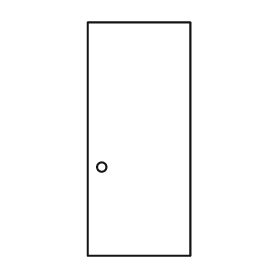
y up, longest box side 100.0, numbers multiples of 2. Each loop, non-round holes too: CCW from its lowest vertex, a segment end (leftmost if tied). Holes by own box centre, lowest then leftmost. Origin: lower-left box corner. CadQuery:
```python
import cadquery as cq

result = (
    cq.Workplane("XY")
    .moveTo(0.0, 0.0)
    .lineTo(44.0, 0.0)
    .lineTo(44.0, 100.0)
    .lineTo(0.0, 100.0)
    .close()
    .moveTo(6.0, 38.0)
    .circle(2.0)
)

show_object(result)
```